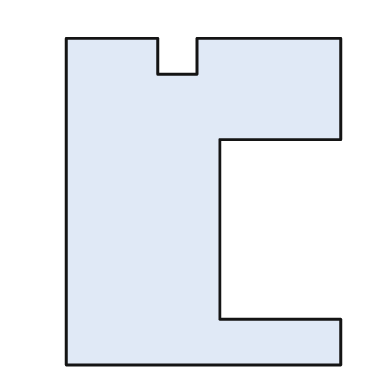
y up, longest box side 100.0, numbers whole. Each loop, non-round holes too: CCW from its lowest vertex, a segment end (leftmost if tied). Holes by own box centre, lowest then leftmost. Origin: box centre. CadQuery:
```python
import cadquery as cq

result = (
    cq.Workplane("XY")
    .moveTo(-42.0, -50.0)
    .lineTo(42.0, -50.0)
    .lineTo(42.0, -36.0)
    .lineTo(5.0, -36.0)
    .lineTo(5.0, 19.0)
    .lineTo(42.0, 19.0)
    .lineTo(42.0, 50.0)
    .lineTo(-2.0, 50.0)
    .lineTo(-2.0, 39.0)
    .lineTo(-14.0, 39.0)
    .lineTo(-14.0, 50.0)
    .lineTo(-42.0, 50.0)
    .close()
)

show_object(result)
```